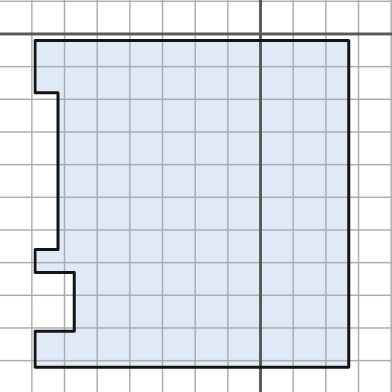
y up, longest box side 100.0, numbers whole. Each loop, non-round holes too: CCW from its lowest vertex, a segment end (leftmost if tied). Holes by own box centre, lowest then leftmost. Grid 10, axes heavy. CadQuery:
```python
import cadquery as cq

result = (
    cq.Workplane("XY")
    .moveTo(-69.0, -102.0)
    .lineTo(27.0, -102.0)
    .lineTo(27.0, -2.0)
    .lineTo(-69.0, -2.0)
    .lineTo(-69.0, -18.0)
    .lineTo(-62.0, -18.0)
    .lineTo(-62.0, -66.0)
    .lineTo(-69.0, -66.0)
    .lineTo(-69.0, -73.0)
    .lineTo(-57.0, -73.0)
    .lineTo(-57.0, -91.0)
    .lineTo(-69.0, -91.0)
    .close()
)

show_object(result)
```